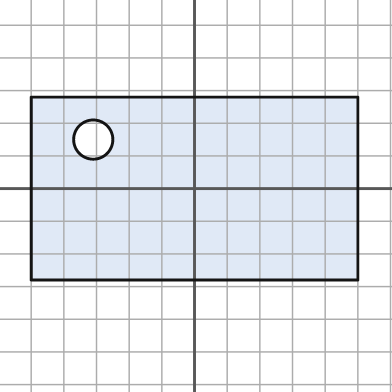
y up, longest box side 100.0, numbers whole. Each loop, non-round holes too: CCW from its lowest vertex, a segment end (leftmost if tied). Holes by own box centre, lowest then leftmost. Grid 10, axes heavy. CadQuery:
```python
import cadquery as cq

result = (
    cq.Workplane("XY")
    .moveTo(-50.0, -28.0)
    .lineTo(50.0, -28.0)
    .lineTo(50.0, 28.0)
    .lineTo(-50.0, 28.0)
    .close()
    .moveTo(-31.0, 15.0)
    .circle(6.0)
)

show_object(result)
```